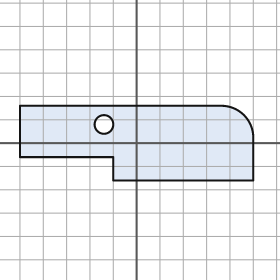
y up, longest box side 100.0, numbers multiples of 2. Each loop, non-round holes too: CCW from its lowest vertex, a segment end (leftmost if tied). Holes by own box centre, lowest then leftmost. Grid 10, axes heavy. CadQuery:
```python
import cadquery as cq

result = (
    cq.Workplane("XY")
    .moveTo(-10.0, -16.0)
    .lineTo(50.0, -16.0)
    .lineTo(50.0, 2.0)
    .threePointArc((46.0, 12.0), (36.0, 16.0))
    .lineTo(-50.0, 16.0)
    .lineTo(-50.0, -6.0)
    .lineTo(-10.0, -6.0)
    .close()
    .moveTo(-14.0, 8.0)
    .circle(4.0)
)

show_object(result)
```